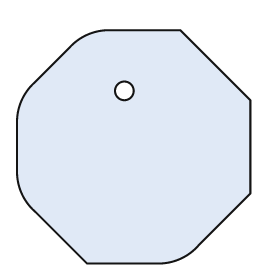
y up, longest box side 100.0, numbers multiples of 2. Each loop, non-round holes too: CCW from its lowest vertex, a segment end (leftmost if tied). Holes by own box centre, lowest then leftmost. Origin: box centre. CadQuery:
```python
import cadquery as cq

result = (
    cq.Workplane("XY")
    .moveTo(-20.0, -50.0)
    .lineTo(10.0, -50.0)
    .threePointArc((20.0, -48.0), (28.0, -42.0))
    .lineTo(50.0, -20.0)
    .lineTo(50.0, 20.0)
    .lineTo(20.0, 50.0)
    .lineTo(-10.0, 50.0)
    .threePointArc((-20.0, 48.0), (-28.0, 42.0))
    .lineTo(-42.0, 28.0)
    .threePointArc((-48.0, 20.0), (-50.0, 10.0))
    .lineTo(-50.0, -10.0)
    .threePointArc((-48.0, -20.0), (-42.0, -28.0))
    .close()
    .moveTo(-4.0, 24.0)
    .circle(4.0)
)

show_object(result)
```